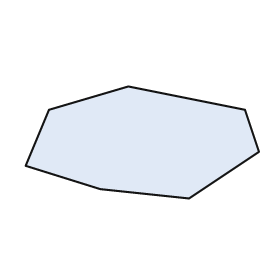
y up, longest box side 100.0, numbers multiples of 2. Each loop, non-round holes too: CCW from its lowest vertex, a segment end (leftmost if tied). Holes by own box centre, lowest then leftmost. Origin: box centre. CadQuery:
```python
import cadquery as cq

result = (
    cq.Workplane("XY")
    .moveTo(20.0, -24.0)
    .lineTo(50.0, -4.0)
    .lineTo(44.0, 14.0)
    .lineTo(-6.0, 24.0)
    .lineTo(-40.0, 14.0)
    .lineTo(-50.0, -10.0)
    .lineTo(-18.0, -20.0)
    .close()
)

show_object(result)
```